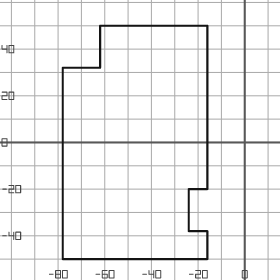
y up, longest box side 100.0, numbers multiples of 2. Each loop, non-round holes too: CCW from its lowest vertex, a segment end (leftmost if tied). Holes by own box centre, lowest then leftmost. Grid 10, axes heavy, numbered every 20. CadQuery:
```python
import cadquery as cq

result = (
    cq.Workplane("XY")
    .moveTo(-78.0, -50.0)
    .lineTo(-16.0, -50.0)
    .lineTo(-16.0, -38.0)
    .lineTo(-24.0, -38.0)
    .lineTo(-24.0, -20.0)
    .lineTo(-16.0, -20.0)
    .lineTo(-16.0, 50.0)
    .lineTo(-62.0, 50.0)
    .lineTo(-62.0, 32.0)
    .lineTo(-78.0, 32.0)
    .close()
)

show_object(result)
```